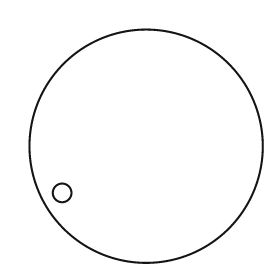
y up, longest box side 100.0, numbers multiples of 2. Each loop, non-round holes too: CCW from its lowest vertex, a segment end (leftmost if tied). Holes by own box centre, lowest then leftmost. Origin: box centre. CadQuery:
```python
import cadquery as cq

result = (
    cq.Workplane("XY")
    .moveTo(0.0, 0.0)
    .circle(50.0)
    .moveTo(-36.0, -20.0)
    .circle(4.0)
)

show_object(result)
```